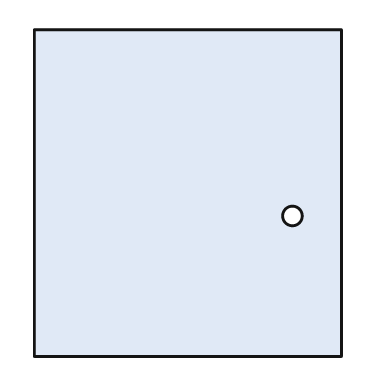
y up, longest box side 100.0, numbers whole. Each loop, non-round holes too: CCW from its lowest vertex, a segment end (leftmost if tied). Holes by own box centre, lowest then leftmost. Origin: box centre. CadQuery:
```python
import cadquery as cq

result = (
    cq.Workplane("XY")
    .moveTo(-47.0, -50.0)
    .lineTo(47.0, -50.0)
    .lineTo(47.0, 50.0)
    .lineTo(-47.0, 50.0)
    .close()
    .moveTo(32.0, -7.0)
    .circle(3.0)
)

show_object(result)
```